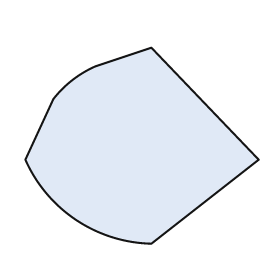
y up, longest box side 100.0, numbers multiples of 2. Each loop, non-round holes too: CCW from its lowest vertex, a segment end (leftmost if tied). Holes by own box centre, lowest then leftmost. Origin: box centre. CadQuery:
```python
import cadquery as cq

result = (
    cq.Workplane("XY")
    .moveTo(4.0, -42.0)
    .lineTo(50.0, -6.0)
    .lineTo(4.0, 42.0)
    .lineTo(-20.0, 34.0)
    .threePointArc((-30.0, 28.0), (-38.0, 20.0))
    .lineTo(-50.0, -6.0)
    .threePointArc((-28.0, -32.0), (4.0, -42.0))
    .close()
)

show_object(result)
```